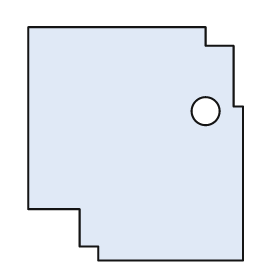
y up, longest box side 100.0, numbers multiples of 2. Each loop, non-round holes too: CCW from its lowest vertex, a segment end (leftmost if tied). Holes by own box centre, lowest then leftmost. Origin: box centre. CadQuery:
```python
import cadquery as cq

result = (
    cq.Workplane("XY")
    .moveTo(-16.0, -50.0)
    .lineTo(46.0, -50.0)
    .lineTo(46.0, 16.0)
    .lineTo(42.0, 16.0)
    .lineTo(42.0, 42.0)
    .lineTo(30.0, 42.0)
    .lineTo(30.0, 50.0)
    .lineTo(-46.0, 50.0)
    .lineTo(-46.0, -28.0)
    .lineTo(-24.0, -28.0)
    .lineTo(-24.0, -44.0)
    .lineTo(-16.0, -44.0)
    .close()
    .moveTo(30.0, 14.0)
    .circle(6.0)
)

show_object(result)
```